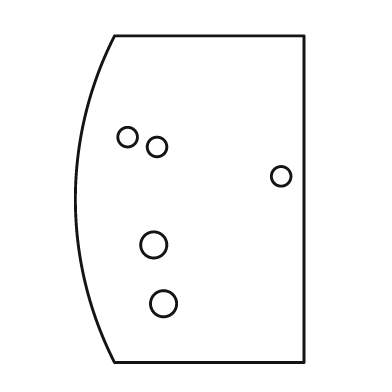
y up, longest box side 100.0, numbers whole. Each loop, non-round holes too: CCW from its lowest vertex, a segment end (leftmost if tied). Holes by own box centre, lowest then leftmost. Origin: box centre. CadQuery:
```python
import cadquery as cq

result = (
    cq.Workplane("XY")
    .moveTo(-23.0, -50.0)
    .lineTo(35.0, -50.0)
    .lineTo(35.0, 50.0)
    .lineTo(-23.0, 50.0)
    .threePointArc((-35.0, 0.0), (-23.0, -50.0))
    .close()
    .moveTo(-8.0, -32.0)
    .circle(4.0)
    .moveTo(-11.0, -14.0)
    .circle(4.0)
    .moveTo(28.0, 7.0)
    .circle(3.0)
    .moveTo(-10.0, 16.0)
    .circle(3.0)
    .moveTo(-19.0, 19.0)
    .circle(3.0)
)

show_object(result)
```